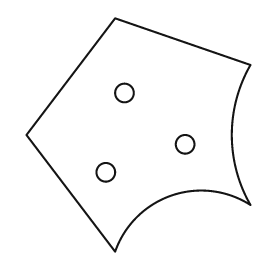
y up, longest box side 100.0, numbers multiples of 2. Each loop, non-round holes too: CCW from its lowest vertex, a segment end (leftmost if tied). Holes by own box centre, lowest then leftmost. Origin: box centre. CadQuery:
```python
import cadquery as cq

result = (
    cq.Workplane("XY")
    .moveTo(-10.0, -50.0)
    .threePointArc((14.0, -26.0), (48.0, -30.0))
    .threePointArc((40.0, 0.0), (48.0, 30.0))
    .lineTo(-10.0, 50.0)
    .lineTo(-48.0, 0.0)
    .close()
    .moveTo(-14.0, -16.0)
    .circle(4.0)
    .moveTo(20.0, -4.0)
    .circle(4.0)
    .moveTo(-6.0, 18.0)
    .circle(4.0)
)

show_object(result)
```